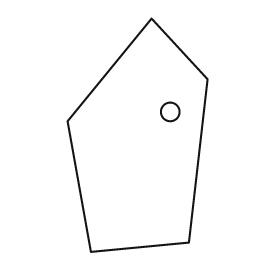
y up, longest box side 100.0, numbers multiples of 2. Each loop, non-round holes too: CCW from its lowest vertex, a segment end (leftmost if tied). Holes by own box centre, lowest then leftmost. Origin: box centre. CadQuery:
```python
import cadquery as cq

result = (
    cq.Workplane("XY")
    .moveTo(-20.0, -50.0)
    .lineTo(22.0, -46.0)
    .lineTo(30.0, 24.0)
    .lineTo(6.0, 50.0)
    .lineTo(-30.0, 6.0)
    .close()
    .moveTo(14.0, 10.0)
    .circle(4.0)
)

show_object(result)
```